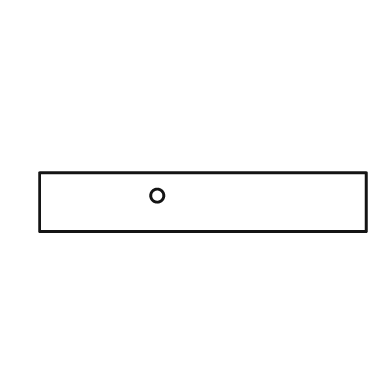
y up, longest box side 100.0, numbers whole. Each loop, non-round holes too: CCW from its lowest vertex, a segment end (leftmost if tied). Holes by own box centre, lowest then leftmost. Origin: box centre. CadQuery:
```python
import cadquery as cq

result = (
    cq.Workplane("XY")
    .moveTo(-50.0, -9.0)
    .lineTo(50.0, -9.0)
    .lineTo(50.0, 9.0)
    .lineTo(-50.0, 9.0)
    .close()
    .moveTo(-14.0, 2.0)
    .circle(2.0)
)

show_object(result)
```